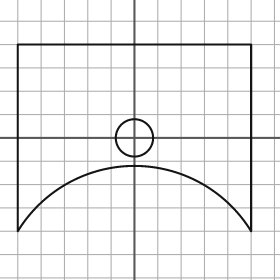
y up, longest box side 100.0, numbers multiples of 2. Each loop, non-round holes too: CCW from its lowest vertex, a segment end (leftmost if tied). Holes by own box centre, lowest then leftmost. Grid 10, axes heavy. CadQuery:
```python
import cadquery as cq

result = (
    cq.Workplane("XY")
    .moveTo(-50.0, -40.0)
    .threePointArc((0.0, -12.0), (50.0, -40.0))
    .lineTo(50.0, 40.0)
    .lineTo(-50.0, 40.0)
    .close()
    .moveTo(0.0, 0.0)
    .circle(8.0)
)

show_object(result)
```